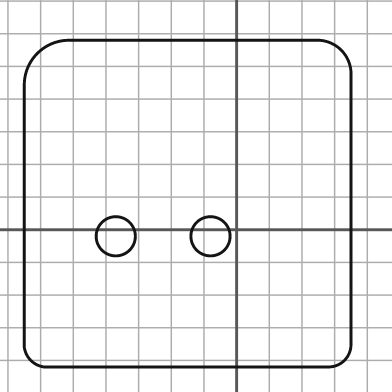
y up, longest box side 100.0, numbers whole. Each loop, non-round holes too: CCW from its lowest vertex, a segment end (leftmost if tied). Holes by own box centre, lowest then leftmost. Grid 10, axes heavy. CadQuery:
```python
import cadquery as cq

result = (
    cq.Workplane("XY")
    .moveTo(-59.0, -42.0)
    .lineTo(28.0, -42.0)
    .threePointArc((33.0, -40.0), (35.0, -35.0))
    .lineTo(35.0, 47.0)
    .threePointArc((32.0, 55.0), (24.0, 58.0))
    .lineTo(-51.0, 58.0)
    .threePointArc((-61.0, 54.0), (-65.0, 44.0))
    .lineTo(-65.0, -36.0)
    .threePointArc((-63.0, -40.0), (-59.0, -42.0))
    .close()
    .moveTo(-37.0, -2.0)
    .circle(6.0)
    .moveTo(-8.0, -2.0)
    .circle(6.0)
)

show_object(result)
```